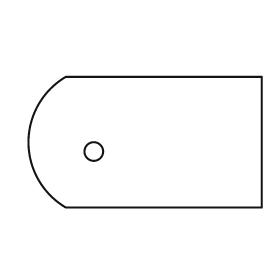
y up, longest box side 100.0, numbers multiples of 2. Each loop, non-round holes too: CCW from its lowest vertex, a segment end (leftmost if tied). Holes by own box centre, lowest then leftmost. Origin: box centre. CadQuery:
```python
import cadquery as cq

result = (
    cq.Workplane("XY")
    .moveTo(-34.0, -28.0)
    .lineTo(50.0, -28.0)
    .lineTo(50.0, 28.0)
    .lineTo(-34.0, 28.0)
    .threePointArc((-50.0, 0.0), (-34.0, -28.0))
    .close()
    .moveTo(-22.0, -4.0)
    .circle(4.0)
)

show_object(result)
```